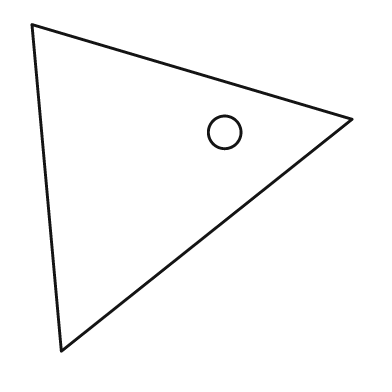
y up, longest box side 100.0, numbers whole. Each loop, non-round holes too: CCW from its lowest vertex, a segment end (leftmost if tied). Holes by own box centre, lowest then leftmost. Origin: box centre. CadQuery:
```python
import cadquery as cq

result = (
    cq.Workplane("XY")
    .moveTo(-40.0, -50.0)
    .lineTo(49.0, 21.0)
    .lineTo(-49.0, 50.0)
    .close()
    .moveTo(10.0, 17.0)
    .circle(5.0)
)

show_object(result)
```